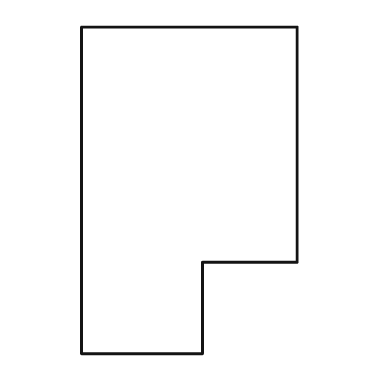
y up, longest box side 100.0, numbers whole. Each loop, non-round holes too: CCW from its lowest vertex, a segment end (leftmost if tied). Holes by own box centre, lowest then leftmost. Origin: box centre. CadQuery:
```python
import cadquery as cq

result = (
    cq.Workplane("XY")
    .moveTo(-33.0, -50.0)
    .lineTo(4.0, -50.0)
    .lineTo(4.0, -22.0)
    .lineTo(33.0, -22.0)
    .lineTo(33.0, 50.0)
    .lineTo(-33.0, 50.0)
    .close()
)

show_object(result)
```